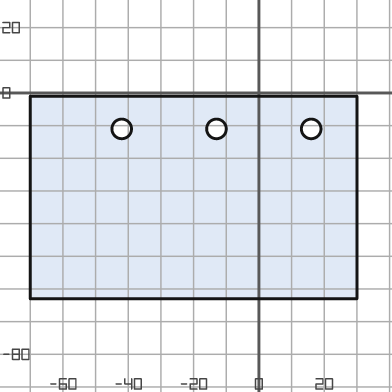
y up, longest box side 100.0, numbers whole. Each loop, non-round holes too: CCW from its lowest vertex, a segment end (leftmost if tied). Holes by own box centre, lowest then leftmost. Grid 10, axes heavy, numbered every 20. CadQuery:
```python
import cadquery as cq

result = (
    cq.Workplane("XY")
    .moveTo(-70.0, -63.0)
    .lineTo(30.0, -63.0)
    .lineTo(30.0, -1.0)
    .lineTo(-70.0, -1.0)
    .close()
    .moveTo(-42.0, -11.0)
    .circle(3.0)
    .moveTo(-13.0, -11.0)
    .circle(3.0)
    .moveTo(16.0, -11.0)
    .circle(3.0)
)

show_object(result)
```